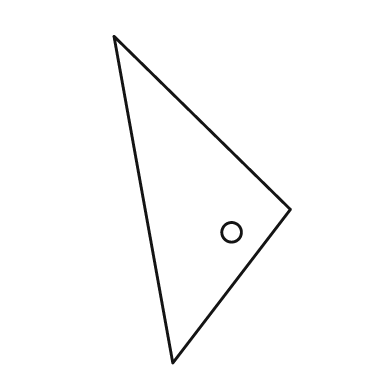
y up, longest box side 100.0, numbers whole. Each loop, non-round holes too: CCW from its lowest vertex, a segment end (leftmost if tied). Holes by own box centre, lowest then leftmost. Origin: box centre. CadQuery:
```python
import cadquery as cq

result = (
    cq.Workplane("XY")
    .moveTo(-9.0, -50.0)
    .lineTo(27.0, -3.0)
    .lineTo(-27.0, 50.0)
    .close()
    .moveTo(9.0, -10.0)
    .circle(3.0)
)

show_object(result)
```